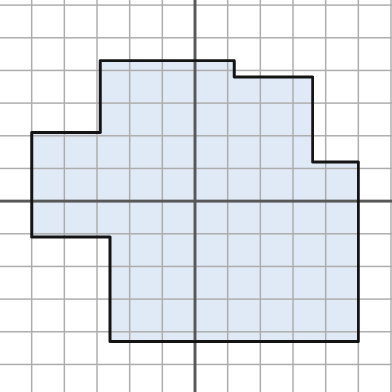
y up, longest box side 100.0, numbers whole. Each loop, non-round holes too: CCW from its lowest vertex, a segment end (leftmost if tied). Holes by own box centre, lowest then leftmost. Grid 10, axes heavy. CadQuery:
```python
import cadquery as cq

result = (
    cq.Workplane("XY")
    .moveTo(-26.0, -43.0)
    .lineTo(50.0, -43.0)
    .lineTo(50.0, 12.0)
    .lineTo(36.0, 12.0)
    .lineTo(36.0, 38.0)
    .lineTo(12.0, 38.0)
    .lineTo(12.0, 43.0)
    .lineTo(-29.0, 43.0)
    .lineTo(-29.0, 21.0)
    .lineTo(-50.0, 21.0)
    .lineTo(-50.0, -11.0)
    .lineTo(-26.0, -11.0)
    .close()
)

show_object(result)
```